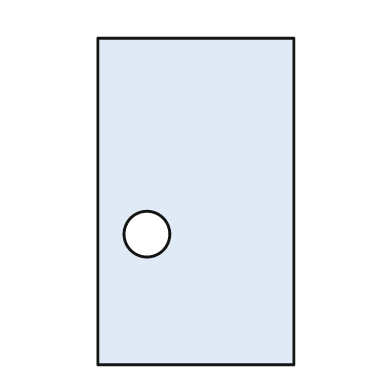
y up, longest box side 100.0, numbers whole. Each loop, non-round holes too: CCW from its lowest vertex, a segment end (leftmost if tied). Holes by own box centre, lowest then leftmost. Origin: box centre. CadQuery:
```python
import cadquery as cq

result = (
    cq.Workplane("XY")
    .moveTo(-30.0, -50.0)
    .lineTo(30.0, -50.0)
    .lineTo(30.0, 50.0)
    .lineTo(-30.0, 50.0)
    .close()
    .moveTo(-15.0, -10.0)
    .circle(7.0)
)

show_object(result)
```